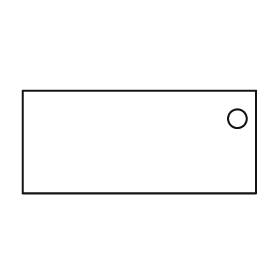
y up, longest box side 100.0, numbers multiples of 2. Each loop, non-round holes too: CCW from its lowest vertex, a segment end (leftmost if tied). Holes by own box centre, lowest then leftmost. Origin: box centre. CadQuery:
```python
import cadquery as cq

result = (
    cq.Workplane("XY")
    .moveTo(-50.0, -22.0)
    .lineTo(50.0, -22.0)
    .lineTo(50.0, 22.0)
    .lineTo(-50.0, 22.0)
    .close()
    .moveTo(42.0, 10.0)
    .circle(4.0)
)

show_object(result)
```